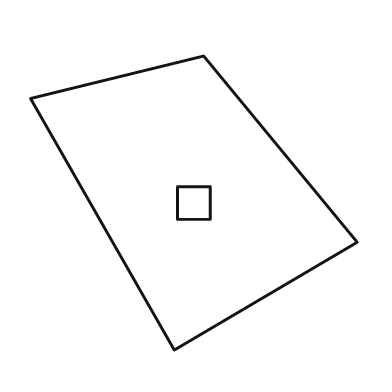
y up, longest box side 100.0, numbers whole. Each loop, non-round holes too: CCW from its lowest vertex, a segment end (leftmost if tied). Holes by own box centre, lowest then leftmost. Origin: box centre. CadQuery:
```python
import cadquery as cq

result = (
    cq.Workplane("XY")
    .moveTo(-6.0, -45.0)
    .lineTo(50.0, -12.0)
    .lineTo(3.0, 45.0)
    .lineTo(-50.0, 32.0)
    .close()
    .moveTo(-5.0, -5.0)
    .lineTo(5.0, -5.0)
    .lineTo(5.0, 5.0)
    .lineTo(-5.0, 5.0)
    .close()
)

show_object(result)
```